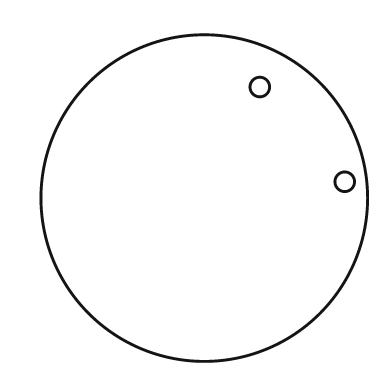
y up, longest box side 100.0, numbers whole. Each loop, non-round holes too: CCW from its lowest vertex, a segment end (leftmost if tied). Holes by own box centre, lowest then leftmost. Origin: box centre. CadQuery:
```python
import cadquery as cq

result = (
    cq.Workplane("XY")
    .moveTo(0.0, 0.0)
    .circle(50.0)
    .moveTo(43.0, 5.0)
    .circle(3.0)
    .moveTo(17.0, 34.0)
    .circle(3.0)
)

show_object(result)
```